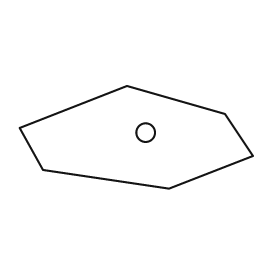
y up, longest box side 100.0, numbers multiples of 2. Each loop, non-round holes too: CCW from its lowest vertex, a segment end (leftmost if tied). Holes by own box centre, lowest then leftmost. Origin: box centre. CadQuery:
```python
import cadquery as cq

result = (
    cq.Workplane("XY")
    .moveTo(14.0, -22.0)
    .lineTo(50.0, -8.0)
    .lineTo(38.0, 10.0)
    .lineTo(-4.0, 22.0)
    .lineTo(-50.0, 4.0)
    .lineTo(-40.0, -14.0)
    .close()
    .moveTo(4.0, 2.0)
    .circle(4.0)
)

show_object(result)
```